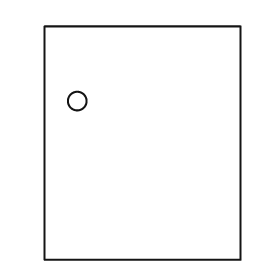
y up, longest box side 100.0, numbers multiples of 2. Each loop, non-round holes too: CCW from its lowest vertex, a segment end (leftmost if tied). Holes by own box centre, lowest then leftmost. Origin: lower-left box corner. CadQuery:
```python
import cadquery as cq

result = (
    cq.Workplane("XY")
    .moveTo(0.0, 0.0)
    .lineTo(84.0, 0.0)
    .lineTo(84.0, 100.0)
    .lineTo(0.0, 100.0)
    .close()
    .moveTo(14.0, 68.0)
    .circle(4.0)
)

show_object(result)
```